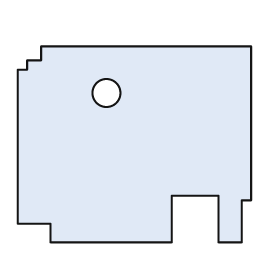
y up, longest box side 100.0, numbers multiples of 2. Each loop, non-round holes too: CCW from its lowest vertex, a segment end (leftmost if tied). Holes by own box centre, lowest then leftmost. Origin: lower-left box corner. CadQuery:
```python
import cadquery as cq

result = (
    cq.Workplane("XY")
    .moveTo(14.0, 0.0)
    .lineTo(66.0, 0.0)
    .lineTo(66.0, 20.0)
    .lineTo(86.0, 20.0)
    .lineTo(86.0, 0.0)
    .lineTo(96.0, 0.0)
    .lineTo(96.0, 18.0)
    .lineTo(100.0, 18.0)
    .lineTo(100.0, 84.0)
    .lineTo(10.0, 84.0)
    .lineTo(10.0, 78.0)
    .lineTo(4.0, 78.0)
    .lineTo(4.0, 74.0)
    .lineTo(0.0, 74.0)
    .lineTo(0.0, 8.0)
    .lineTo(14.0, 8.0)
    .close()
    .moveTo(38.0, 64.0)
    .circle(6.0)
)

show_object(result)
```